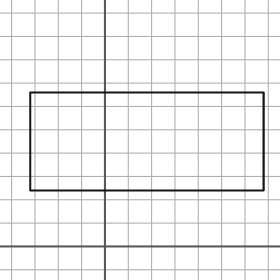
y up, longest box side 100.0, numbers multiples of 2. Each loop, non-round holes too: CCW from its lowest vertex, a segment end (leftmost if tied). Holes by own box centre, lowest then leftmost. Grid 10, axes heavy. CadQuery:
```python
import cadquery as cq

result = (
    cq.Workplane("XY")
    .moveTo(-32.0, 24.0)
    .lineTo(68.0, 24.0)
    .lineTo(68.0, 66.0)
    .lineTo(-32.0, 66.0)
    .close()
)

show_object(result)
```